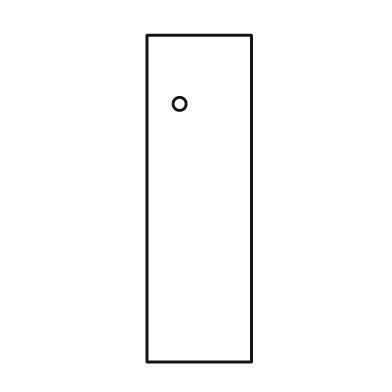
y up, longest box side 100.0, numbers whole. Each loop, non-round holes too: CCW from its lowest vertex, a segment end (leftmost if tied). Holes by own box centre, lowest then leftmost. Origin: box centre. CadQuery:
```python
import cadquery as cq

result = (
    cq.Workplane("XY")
    .moveTo(-16.0, -50.0)
    .lineTo(16.0, -50.0)
    .lineTo(16.0, 50.0)
    .lineTo(-16.0, 50.0)
    .close()
    .moveTo(-6.0, 29.0)
    .circle(2.0)
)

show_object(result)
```